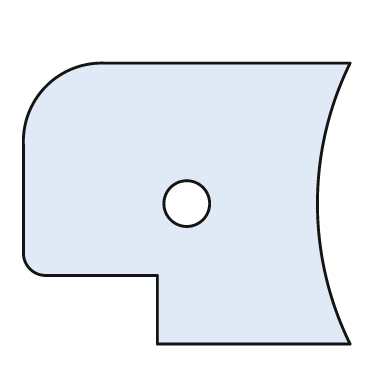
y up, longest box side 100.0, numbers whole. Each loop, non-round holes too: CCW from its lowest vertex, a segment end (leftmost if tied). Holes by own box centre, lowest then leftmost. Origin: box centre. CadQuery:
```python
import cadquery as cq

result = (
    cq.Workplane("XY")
    .moveTo(-9.0, -43.0)
    .lineTo(50.0, -43.0)
    .threePointArc((40.0, 0.0), (50.0, 43.0))
    .lineTo(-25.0, 43.0)
    .threePointArc((-43.0, 36.0), (-50.0, 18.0))
    .lineTo(-50.0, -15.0)
    .threePointArc((-48.0, -20.0), (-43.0, -22.0))
    .lineTo(-9.0, -22.0)
    .close()
    .moveTo(0.0, 0.0)
    .circle(7.0)
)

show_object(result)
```